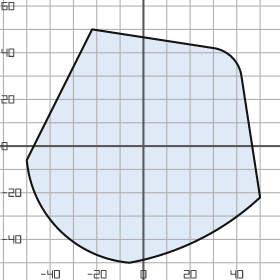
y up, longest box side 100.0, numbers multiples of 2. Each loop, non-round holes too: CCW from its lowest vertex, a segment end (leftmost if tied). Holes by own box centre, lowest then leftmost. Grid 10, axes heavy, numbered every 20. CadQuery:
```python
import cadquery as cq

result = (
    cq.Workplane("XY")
    .moveTo(-6.0, -50.0)
    .threePointArc((24.0, -40.0), (50.0, -22.0))
    .lineTo(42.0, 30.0)
    .threePointArc((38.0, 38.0), (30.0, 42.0))
    .lineTo(-22.0, 50.0)
    .lineTo(-50.0, -6.0)
    .threePointArc((-36.0, -36.0), (-6.0, -50.0))
    .close()
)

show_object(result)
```